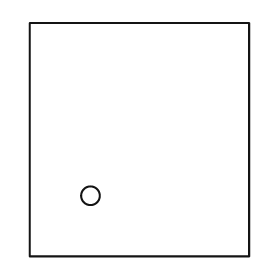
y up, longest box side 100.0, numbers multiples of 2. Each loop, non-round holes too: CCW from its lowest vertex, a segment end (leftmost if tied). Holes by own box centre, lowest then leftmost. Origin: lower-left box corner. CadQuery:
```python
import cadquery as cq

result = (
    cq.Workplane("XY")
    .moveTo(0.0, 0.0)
    .lineTo(94.0, 0.0)
    .lineTo(94.0, 100.0)
    .lineTo(0.0, 100.0)
    .close()
    .moveTo(26.0, 26.0)
    .circle(4.0)
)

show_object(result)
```